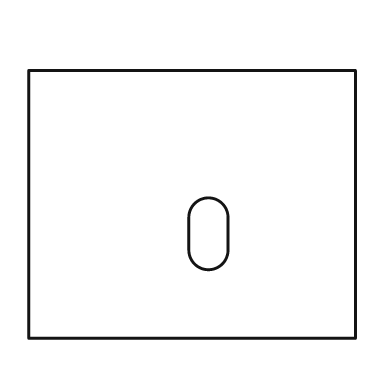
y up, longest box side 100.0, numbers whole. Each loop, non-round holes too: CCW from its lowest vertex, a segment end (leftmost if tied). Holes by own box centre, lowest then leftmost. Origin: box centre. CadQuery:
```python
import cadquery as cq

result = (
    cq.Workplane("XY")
    .moveTo(-50.0, -41.0)
    .lineTo(50.0, -41.0)
    .lineTo(50.0, 41.0)
    .lineTo(-50.0, 41.0)
    .close()
    .moveTo(-1.0, -14.0)
    .threePointArc((5.0, -20.0), (11.0, -14.0))
    .lineTo(11.0, -4.0)
    .threePointArc((5.0, 2.0), (-1.0, -4.0))
    .close()
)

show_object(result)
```